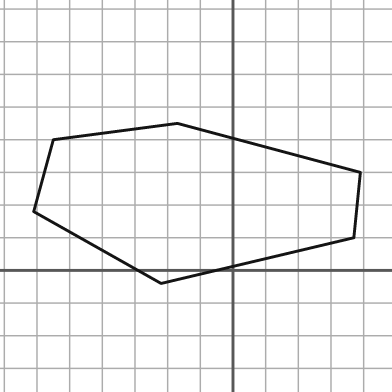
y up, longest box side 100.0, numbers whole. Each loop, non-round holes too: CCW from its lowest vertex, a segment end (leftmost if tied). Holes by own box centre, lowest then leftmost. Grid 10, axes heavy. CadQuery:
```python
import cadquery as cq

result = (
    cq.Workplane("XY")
    .moveTo(-22.0, -4.0)
    .lineTo(37.0, 10.0)
    .lineTo(39.0, 30.0)
    .lineTo(-17.0, 45.0)
    .lineTo(-55.0, 40.0)
    .lineTo(-61.0, 18.0)
    .close()
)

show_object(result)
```